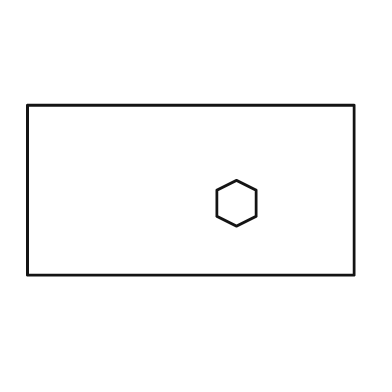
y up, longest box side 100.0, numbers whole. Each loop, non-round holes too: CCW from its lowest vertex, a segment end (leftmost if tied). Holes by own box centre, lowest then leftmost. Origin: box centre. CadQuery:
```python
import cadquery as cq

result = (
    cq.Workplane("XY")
    .moveTo(-50.0, -26.0)
    .lineTo(50.0, -26.0)
    .lineTo(50.0, 26.0)
    .lineTo(-50.0, 26.0)
    .close()
    .moveTo(14.0, -11.0)
    .lineTo(20.0, -8.0)
    .lineTo(20.0, 0.0)
    .lineTo(14.0, 3.0)
    .lineTo(8.0, 0.0)
    .lineTo(8.0, -8.0)
    .close()
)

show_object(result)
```